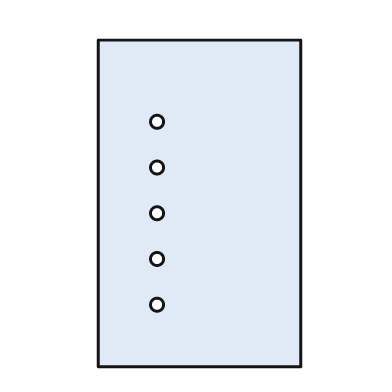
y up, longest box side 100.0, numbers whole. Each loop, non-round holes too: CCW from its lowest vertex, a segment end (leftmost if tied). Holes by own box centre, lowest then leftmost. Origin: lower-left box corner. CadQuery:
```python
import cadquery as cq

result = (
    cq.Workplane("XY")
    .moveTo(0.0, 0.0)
    .lineTo(62.0, 0.0)
    .lineTo(62.0, 100.0)
    .lineTo(0.0, 100.0)
    .close()
    .moveTo(18.0, 19.0)
    .circle(2.0)
    .moveTo(18.0, 33.0)
    .circle(2.0)
    .moveTo(18.0, 47.0)
    .circle(2.0)
    .moveTo(18.0, 61.0)
    .circle(2.0)
    .moveTo(18.0, 75.0)
    .circle(2.0)
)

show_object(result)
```